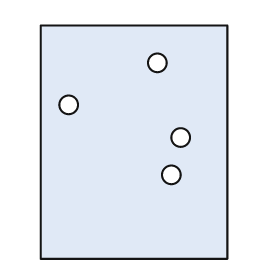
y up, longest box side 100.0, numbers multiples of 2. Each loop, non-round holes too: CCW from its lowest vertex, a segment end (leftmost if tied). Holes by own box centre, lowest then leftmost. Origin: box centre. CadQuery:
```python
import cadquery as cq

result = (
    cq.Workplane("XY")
    .moveTo(-40.0, -50.0)
    .lineTo(40.0, -50.0)
    .lineTo(40.0, 50.0)
    .lineTo(-40.0, 50.0)
    .close()
    .moveTo(16.0, -14.0)
    .circle(4.0)
    .moveTo(20.0, 2.0)
    .circle(4.0)
    .moveTo(-28.0, 16.0)
    .circle(4.0)
    .moveTo(10.0, 34.0)
    .circle(4.0)
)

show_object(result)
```